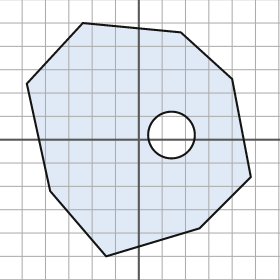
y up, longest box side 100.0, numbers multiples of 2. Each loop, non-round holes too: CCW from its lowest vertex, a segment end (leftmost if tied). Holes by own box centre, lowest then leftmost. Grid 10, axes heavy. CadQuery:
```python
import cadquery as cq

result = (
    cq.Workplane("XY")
    .moveTo(-14.0, -50.0)
    .lineTo(26.0, -38.0)
    .lineTo(48.0, -16.0)
    .lineTo(40.0, 26.0)
    .lineTo(18.0, 46.0)
    .lineTo(-24.0, 50.0)
    .lineTo(-48.0, 24.0)
    .lineTo(-38.0, -22.0)
    .close()
    .moveTo(14.0, 2.0)
    .circle(10.0)
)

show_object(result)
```